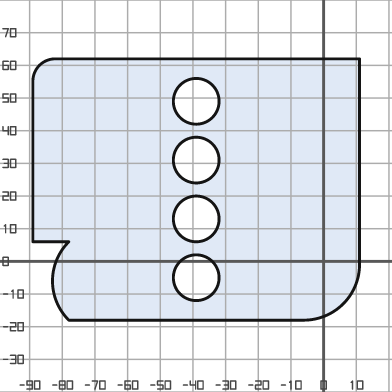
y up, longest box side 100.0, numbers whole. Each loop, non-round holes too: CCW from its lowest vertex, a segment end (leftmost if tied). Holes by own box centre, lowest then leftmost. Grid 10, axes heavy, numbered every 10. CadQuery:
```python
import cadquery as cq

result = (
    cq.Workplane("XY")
    .moveTo(-78.0, -18.0)
    .lineTo(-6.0, -18.0)
    .threePointArc((6.0, -13.0), (11.0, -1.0))
    .lineTo(11.0, 62.0)
    .lineTo(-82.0, 62.0)
    .threePointArc((-87.0, 60.0), (-89.0, 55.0))
    .lineTo(-89.0, 6.0)
    .lineTo(-78.0, 6.0)
    .threePointArc((-83.0, -6.0), (-78.0, -18.0))
    .close()
    .moveTo(-39.0, -5.0)
    .circle(7.0)
    .moveTo(-39.0, 13.0)
    .circle(7.0)
    .moveTo(-39.0, 31.0)
    .circle(7.0)
    .moveTo(-39.0, 49.0)
    .circle(7.0)
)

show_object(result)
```